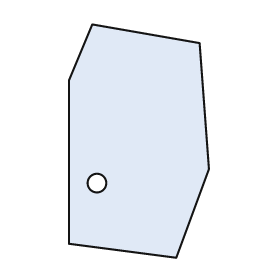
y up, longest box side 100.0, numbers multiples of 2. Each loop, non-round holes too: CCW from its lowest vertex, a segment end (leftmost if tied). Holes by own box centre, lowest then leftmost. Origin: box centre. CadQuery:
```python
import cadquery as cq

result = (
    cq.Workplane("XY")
    .moveTo(16.0, -50.0)
    .lineTo(30.0, -12.0)
    .lineTo(26.0, 42.0)
    .lineTo(-20.0, 50.0)
    .lineTo(-30.0, 26.0)
    .lineTo(-30.0, -44.0)
    .close()
    .moveTo(-18.0, -18.0)
    .circle(4.0)
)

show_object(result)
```